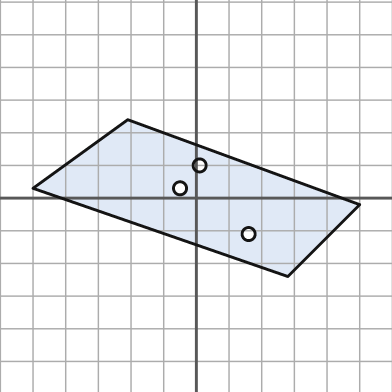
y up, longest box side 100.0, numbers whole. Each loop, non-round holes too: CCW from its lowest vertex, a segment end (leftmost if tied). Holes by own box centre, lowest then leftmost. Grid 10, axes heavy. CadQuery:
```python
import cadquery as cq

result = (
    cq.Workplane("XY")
    .moveTo(28.0, -24.0)
    .lineTo(50.0, -2.0)
    .lineTo(-21.0, 24.0)
    .lineTo(-50.0, 3.0)
    .close()
    .moveTo(16.0, -11.0)
    .circle(2.0)
    .moveTo(-5.0, 3.0)
    .circle(2.0)
    .moveTo(1.0, 10.0)
    .circle(2.0)
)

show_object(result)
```